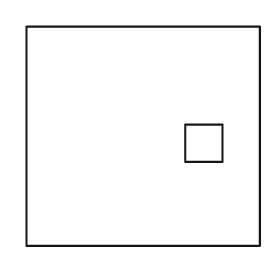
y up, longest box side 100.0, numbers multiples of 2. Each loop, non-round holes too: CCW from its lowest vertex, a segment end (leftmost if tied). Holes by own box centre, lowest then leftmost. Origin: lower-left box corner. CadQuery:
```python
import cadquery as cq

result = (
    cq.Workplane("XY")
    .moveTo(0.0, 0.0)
    .lineTo(100.0, 0.0)
    .lineTo(100.0, 94.0)
    .lineTo(0.0, 94.0)
    .close()
    .moveTo(68.0, 36.0)
    .lineTo(84.0, 36.0)
    .lineTo(84.0, 52.0)
    .lineTo(68.0, 52.0)
    .close()
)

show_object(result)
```